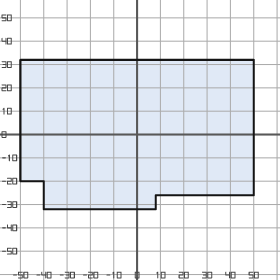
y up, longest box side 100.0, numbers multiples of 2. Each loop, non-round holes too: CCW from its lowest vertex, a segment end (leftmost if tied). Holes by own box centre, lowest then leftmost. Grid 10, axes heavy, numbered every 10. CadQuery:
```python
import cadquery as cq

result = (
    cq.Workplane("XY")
    .moveTo(-40.0, -32.0)
    .lineTo(8.0, -32.0)
    .lineTo(8.0, -26.0)
    .lineTo(50.0, -26.0)
    .lineTo(50.0, 32.0)
    .lineTo(-50.0, 32.0)
    .lineTo(-50.0, -20.0)
    .lineTo(-40.0, -20.0)
    .close()
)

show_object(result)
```